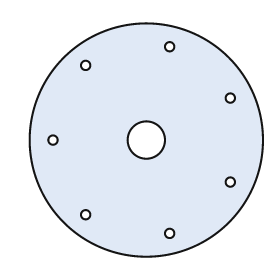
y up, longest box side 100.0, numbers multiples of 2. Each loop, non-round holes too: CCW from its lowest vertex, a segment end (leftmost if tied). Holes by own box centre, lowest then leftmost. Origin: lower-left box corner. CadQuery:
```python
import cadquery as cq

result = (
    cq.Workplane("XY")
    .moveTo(50.0, 50.0)
    .circle(50.0)
    .moveTo(60.0, 10.0)
    .circle(2.0)
    .moveTo(24.0, 18.0)
    .circle(2.0)
    .moveTo(86.0, 32.0)
    .circle(2.0)
    .moveTo(10.0, 50.0)
    .circle(2.0)
    .moveTo(50.0, 50.0)
    .circle(8.0)
    .moveTo(86.0, 68.0)
    .circle(2.0)
    .moveTo(24.0, 82.0)
    .circle(2.0)
    .moveTo(60.0, 90.0)
    .circle(2.0)
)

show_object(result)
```